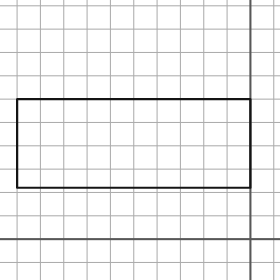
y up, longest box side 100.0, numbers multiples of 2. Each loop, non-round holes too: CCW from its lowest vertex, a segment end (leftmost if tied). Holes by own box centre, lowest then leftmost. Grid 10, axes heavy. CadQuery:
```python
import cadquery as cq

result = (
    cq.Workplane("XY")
    .moveTo(-100.0, 22.0)
    .lineTo(0.0, 22.0)
    .lineTo(0.0, 60.0)
    .lineTo(-100.0, 60.0)
    .close()
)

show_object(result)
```